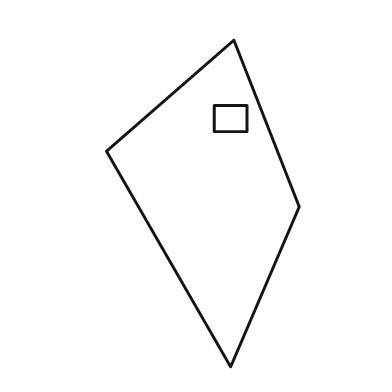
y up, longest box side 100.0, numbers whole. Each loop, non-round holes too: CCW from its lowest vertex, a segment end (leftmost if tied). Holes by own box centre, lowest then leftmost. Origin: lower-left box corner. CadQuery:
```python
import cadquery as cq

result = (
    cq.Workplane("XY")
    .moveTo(38.0, 0.0)
    .lineTo(59.0, 49.0)
    .lineTo(39.0, 100.0)
    .lineTo(0.0, 66.0)
    .close()
    .moveTo(33.0, 72.0)
    .lineTo(43.0, 72.0)
    .lineTo(43.0, 80.0)
    .lineTo(33.0, 80.0)
    .close()
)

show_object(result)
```